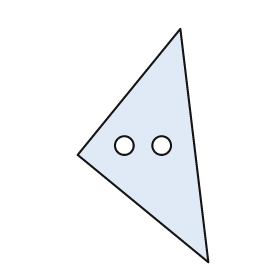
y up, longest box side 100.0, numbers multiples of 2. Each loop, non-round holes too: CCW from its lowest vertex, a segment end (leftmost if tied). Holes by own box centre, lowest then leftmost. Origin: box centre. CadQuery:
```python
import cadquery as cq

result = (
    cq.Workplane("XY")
    .moveTo(28.0, -50.0)
    .lineTo(16.0, 50.0)
    .lineTo(-28.0, -4.0)
    .close()
    .moveTo(-8.0, 0.0)
    .circle(4.0)
    .moveTo(8.0, 0.0)
    .circle(4.0)
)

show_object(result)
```